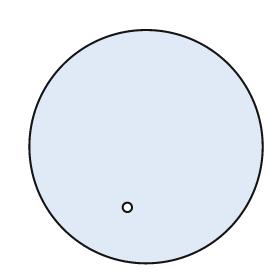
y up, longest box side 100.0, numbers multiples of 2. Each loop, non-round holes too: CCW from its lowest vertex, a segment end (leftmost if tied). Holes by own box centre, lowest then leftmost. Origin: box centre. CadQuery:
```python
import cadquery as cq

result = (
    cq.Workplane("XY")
    .moveTo(0.0, 0.0)
    .circle(50.0)
    .moveTo(-8.0, -26.0)
    .circle(2.0)
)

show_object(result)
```